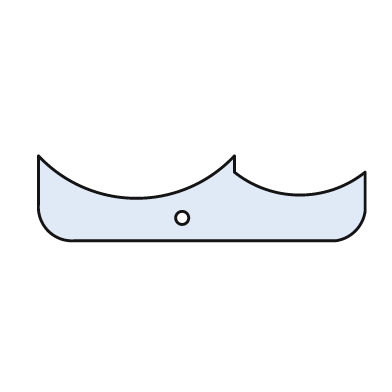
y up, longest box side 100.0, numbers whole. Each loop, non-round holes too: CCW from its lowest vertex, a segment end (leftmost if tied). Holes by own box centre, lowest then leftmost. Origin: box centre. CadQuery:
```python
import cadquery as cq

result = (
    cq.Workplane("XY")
    .moveTo(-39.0, -13.0)
    .lineTo(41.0, -13.0)
    .threePointArc((47.0, -10.0), (50.0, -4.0))
    .lineTo(50.0, 8.0)
    .threePointArc((30.0, 1.0), (10.0, 8.0))
    .lineTo(10.0, 13.0)
    .threePointArc((-20.0, 0.0), (-50.0, 13.0))
    .lineTo(-50.0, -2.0)
    .threePointArc((-47.0, -10.0), (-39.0, -13.0))
    .close()
    .moveTo(-6.0, -6.0)
    .circle(2.0)
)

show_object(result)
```